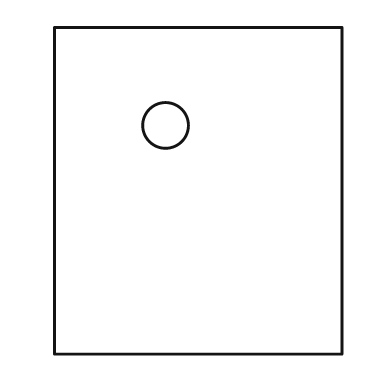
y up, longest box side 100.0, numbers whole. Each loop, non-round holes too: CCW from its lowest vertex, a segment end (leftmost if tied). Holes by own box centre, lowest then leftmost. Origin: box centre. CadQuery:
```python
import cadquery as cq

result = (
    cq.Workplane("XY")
    .moveTo(-44.0, -50.0)
    .lineTo(44.0, -50.0)
    .lineTo(44.0, 50.0)
    .lineTo(-44.0, 50.0)
    .close()
    .moveTo(-10.0, 20.0)
    .circle(7.0)
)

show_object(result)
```